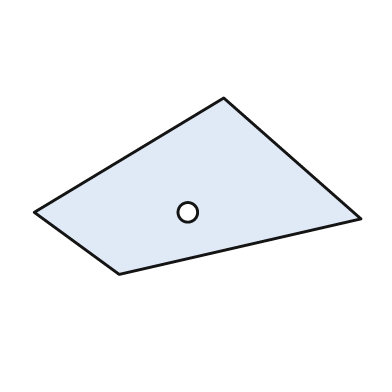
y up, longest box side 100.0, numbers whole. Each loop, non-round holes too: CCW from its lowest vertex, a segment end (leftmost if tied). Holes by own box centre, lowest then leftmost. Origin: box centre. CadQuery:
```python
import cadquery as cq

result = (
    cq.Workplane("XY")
    .moveTo(-24.0, -27.0)
    .lineTo(50.0, -10.0)
    .lineTo(8.0, 27.0)
    .lineTo(-50.0, -8.0)
    .close()
    .moveTo(-3.0, -8.0)
    .circle(3.0)
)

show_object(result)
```